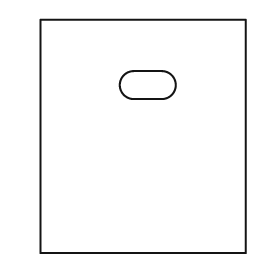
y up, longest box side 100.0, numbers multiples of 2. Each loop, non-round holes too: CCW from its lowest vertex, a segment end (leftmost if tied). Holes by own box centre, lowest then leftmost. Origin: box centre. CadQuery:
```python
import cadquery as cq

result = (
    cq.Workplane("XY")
    .moveTo(-44.0, -50.0)
    .lineTo(44.0, -50.0)
    .lineTo(44.0, 50.0)
    .lineTo(-44.0, 50.0)
    .close()
    .moveTo(-4.0, 16.0)
    .lineTo(8.0, 16.0)
    .threePointArc((14.0, 22.0), (8.0, 28.0))
    .lineTo(-4.0, 28.0)
    .threePointArc((-10.0, 22.0), (-4.0, 16.0))
    .close()
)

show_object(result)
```